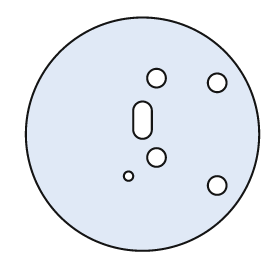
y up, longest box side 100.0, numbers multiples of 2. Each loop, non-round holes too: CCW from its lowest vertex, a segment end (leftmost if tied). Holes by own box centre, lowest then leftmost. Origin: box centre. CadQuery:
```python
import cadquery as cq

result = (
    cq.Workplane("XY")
    .moveTo(0.0, 0.0)
    .circle(50.0)
    .moveTo(32.0, -22.0)
    .circle(4.0)
    .moveTo(-6.0, -18.0)
    .circle(2.0)
    .moveTo(6.0, -10.0)
    .circle(4.0)
    .moveTo(-4.0, 2.0)
    .threePointArc((0.0, -2.0), (4.0, 2.0))
    .lineTo(4.0, 10.0)
    .threePointArc((0.0, 14.0), (-4.0, 10.0))
    .close()
    .moveTo(32.0, 22.0)
    .circle(4.0)
    .moveTo(6.0, 24.0)
    .circle(4.0)
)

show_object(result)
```